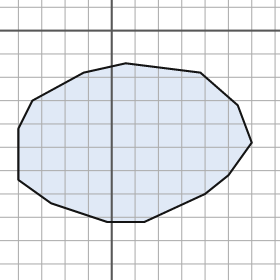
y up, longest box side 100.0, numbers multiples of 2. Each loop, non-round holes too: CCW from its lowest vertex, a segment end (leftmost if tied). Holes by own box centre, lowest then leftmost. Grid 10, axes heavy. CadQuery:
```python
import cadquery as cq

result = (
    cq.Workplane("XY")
    .moveTo(-2.0, -82.0)
    .lineTo(14.0, -82.0)
    .lineTo(40.0, -70.0)
    .lineTo(50.0, -62.0)
    .lineTo(60.0, -48.0)
    .lineTo(54.0, -32.0)
    .lineTo(38.0, -18.0)
    .lineTo(6.0, -14.0)
    .lineTo(-12.0, -18.0)
    .lineTo(-34.0, -30.0)
    .lineTo(-40.0, -42.0)
    .lineTo(-40.0, -64.0)
    .lineTo(-26.0, -74.0)
    .close()
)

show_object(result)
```